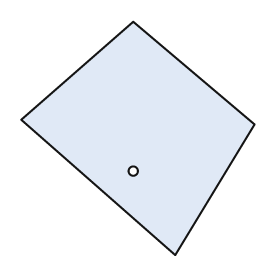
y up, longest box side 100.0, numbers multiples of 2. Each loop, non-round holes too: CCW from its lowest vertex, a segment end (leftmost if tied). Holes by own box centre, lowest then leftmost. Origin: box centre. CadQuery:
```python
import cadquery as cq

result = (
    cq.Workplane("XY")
    .moveTo(16.0, -50.0)
    .lineTo(50.0, 6.0)
    .lineTo(-2.0, 50.0)
    .lineTo(-50.0, 8.0)
    .close()
    .moveTo(-2.0, -14.0)
    .circle(2.0)
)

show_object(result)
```